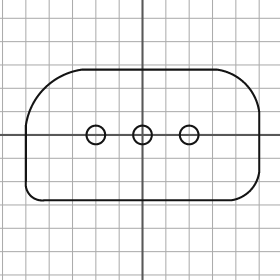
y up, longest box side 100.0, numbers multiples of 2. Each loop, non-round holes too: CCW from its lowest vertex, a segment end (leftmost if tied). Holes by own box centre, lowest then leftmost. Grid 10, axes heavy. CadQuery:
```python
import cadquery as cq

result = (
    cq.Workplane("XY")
    .moveTo(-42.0, -28.0)
    .lineTo(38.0, -28.0)
    .threePointArc((46.0, -24.0), (50.0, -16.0))
    .lineTo(50.0, 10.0)
    .threePointArc((44.0, 22.0), (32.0, 28.0))
    .lineTo(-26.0, 28.0)
    .threePointArc((-42.0, 20.0), (-50.0, 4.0))
    .lineTo(-50.0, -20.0)
    .threePointArc((-48.0, -26.0), (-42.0, -28.0))
    .close()
    .moveTo(-20.0, 0.0)
    .circle(4.0)
    .moveTo(0.0, 0.0)
    .circle(4.0)
    .moveTo(20.0, 0.0)
    .circle(4.0)
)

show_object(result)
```